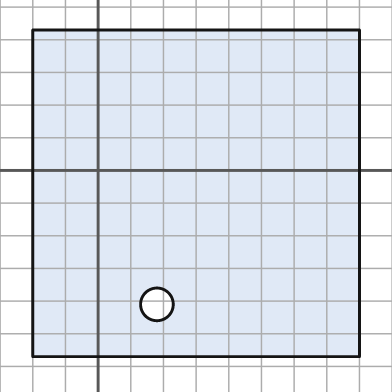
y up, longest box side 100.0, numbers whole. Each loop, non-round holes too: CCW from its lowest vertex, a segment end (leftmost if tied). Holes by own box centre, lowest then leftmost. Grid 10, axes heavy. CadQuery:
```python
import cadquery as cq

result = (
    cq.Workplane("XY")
    .moveTo(-20.0, -57.0)
    .lineTo(80.0, -57.0)
    .lineTo(80.0, 43.0)
    .lineTo(-20.0, 43.0)
    .close()
    .moveTo(18.0, -41.0)
    .circle(5.0)
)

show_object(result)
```